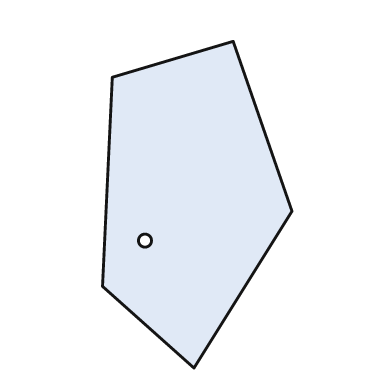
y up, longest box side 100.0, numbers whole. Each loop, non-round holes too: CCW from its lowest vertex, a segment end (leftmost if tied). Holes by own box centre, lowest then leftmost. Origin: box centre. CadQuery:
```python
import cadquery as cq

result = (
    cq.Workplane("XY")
    .moveTo(-1.0, -50.0)
    .lineTo(29.0, -2.0)
    .lineTo(11.0, 50.0)
    .lineTo(-26.0, 39.0)
    .lineTo(-29.0, -25.0)
    .close()
    .moveTo(-16.0, -11.0)
    .circle(2.0)
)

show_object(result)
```